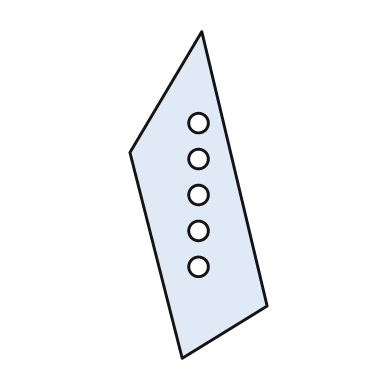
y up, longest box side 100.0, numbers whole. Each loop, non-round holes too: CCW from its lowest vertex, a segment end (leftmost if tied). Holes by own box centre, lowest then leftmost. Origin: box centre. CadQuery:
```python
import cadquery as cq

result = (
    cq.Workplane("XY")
    .moveTo(-5.0, -50.0)
    .lineTo(21.0, -34.0)
    .lineTo(1.0, 50.0)
    .lineTo(-21.0, 13.0)
    .close()
    .moveTo(0.0, -22.0)
    .circle(3.0)
    .moveTo(0.0, -11.0)
    .circle(3.0)
    .moveTo(0.0, 0.0)
    .circle(3.0)
    .moveTo(0.0, 11.0)
    .circle(3.0)
    .moveTo(0.0, 22.0)
    .circle(3.0)
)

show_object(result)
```